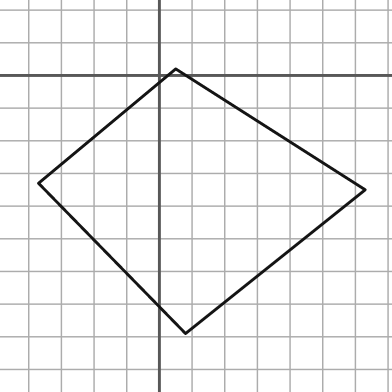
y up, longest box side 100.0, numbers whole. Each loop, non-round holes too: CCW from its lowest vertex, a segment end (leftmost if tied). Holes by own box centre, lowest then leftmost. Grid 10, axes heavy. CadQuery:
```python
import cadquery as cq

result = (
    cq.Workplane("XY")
    .moveTo(8.0, -79.0)
    .lineTo(63.0, -35.0)
    .lineTo(5.0, 2.0)
    .lineTo(-37.0, -33.0)
    .close()
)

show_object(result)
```